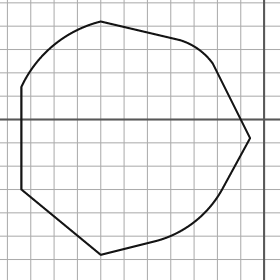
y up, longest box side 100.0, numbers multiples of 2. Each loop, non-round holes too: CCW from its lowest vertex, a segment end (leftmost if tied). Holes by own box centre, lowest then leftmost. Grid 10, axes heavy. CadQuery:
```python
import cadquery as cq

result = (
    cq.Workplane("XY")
    .moveTo(-70.0, -58.0)
    .lineTo(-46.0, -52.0)
    .threePointArc((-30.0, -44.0), (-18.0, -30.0))
    .lineTo(-6.0, -8.0)
    .lineTo(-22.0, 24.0)
    .threePointArc((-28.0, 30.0), (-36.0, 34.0))
    .lineTo(-70.0, 42.0)
    .threePointArc((-90.0, 32.0), (-104.0, 14.0))
    .lineTo(-104.0, -30.0)
    .close()
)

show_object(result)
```